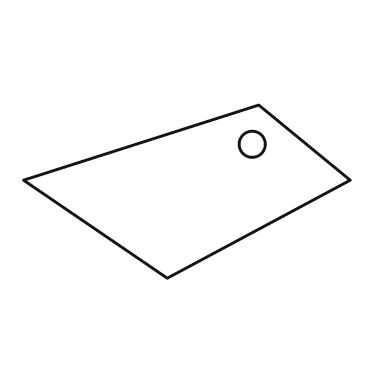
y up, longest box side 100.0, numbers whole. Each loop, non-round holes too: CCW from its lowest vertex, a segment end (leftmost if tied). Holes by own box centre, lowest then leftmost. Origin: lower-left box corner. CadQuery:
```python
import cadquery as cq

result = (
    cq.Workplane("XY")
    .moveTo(44.0, 0.0)
    .lineTo(100.0, 30.0)
    .lineTo(72.0, 53.0)
    .lineTo(0.0, 30.0)
    .close()
    .moveTo(70.0, 41.0)
    .circle(4.0)
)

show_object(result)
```